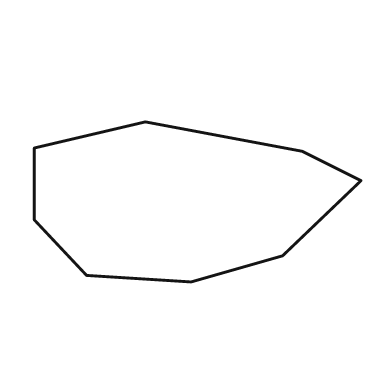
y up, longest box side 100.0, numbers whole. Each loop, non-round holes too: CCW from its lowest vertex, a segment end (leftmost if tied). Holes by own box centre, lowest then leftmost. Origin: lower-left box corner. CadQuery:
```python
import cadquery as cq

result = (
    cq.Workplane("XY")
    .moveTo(48.0, 0.0)
    .lineTo(76.0, 8.0)
    .lineTo(100.0, 31.0)
    .lineTo(82.0, 40.0)
    .lineTo(34.0, 49.0)
    .lineTo(0.0, 41.0)
    .lineTo(0.0, 19.0)
    .lineTo(16.0, 2.0)
    .close()
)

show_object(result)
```